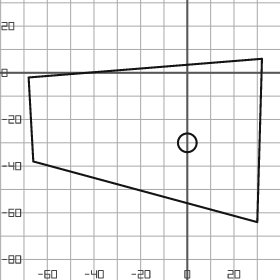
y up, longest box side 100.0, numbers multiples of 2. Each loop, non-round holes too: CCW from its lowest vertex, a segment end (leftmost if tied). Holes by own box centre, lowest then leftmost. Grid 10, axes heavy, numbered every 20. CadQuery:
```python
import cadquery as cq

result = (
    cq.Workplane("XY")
    .moveTo(30.0, -64.0)
    .lineTo(32.0, 6.0)
    .lineTo(-68.0, -2.0)
    .lineTo(-66.0, -38.0)
    .close()
    .moveTo(0.0, -30.0)
    .circle(4.0)
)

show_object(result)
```